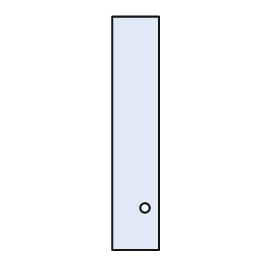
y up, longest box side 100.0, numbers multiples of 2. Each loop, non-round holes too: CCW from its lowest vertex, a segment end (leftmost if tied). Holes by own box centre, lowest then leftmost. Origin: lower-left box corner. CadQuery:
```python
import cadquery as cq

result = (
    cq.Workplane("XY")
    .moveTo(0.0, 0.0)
    .lineTo(20.0, 0.0)
    .lineTo(20.0, 100.0)
    .lineTo(0.0, 100.0)
    .close()
    .moveTo(14.0, 18.0)
    .circle(2.0)
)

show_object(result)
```